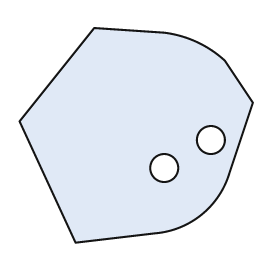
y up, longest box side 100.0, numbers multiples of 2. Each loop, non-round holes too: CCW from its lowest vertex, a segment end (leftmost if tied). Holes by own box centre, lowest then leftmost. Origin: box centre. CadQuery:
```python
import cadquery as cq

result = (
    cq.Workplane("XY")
    .moveTo(-26.0, -46.0)
    .lineTo(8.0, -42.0)
    .threePointArc((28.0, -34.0), (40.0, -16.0))
    .lineTo(50.0, 14.0)
    .lineTo(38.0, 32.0)
    .threePointArc((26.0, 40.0), (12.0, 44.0))
    .lineTo(-18.0, 46.0)
    .lineTo(-50.0, 6.0)
    .close()
    .moveTo(12.0, -14.0)
    .circle(6.0)
    .moveTo(32.0, -2.0)
    .circle(6.0)
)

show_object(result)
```